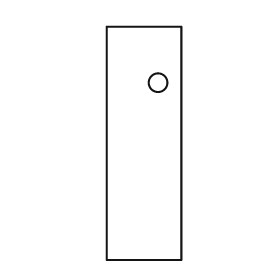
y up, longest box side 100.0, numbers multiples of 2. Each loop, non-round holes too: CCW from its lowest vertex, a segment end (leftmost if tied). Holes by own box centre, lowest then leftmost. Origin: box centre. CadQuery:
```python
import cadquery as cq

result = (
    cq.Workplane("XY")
    .moveTo(-16.0, -50.0)
    .lineTo(16.0, -50.0)
    .lineTo(16.0, 50.0)
    .lineTo(-16.0, 50.0)
    .close()
    .moveTo(6.0, 26.0)
    .circle(4.0)
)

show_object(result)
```